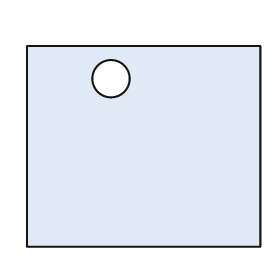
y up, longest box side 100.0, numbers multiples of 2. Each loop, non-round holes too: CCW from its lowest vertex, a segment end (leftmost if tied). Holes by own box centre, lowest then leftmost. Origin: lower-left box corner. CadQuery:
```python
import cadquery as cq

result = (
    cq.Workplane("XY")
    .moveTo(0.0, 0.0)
    .lineTo(100.0, 0.0)
    .lineTo(100.0, 86.0)
    .lineTo(0.0, 86.0)
    .close()
    .moveTo(36.0, 72.0)
    .circle(8.0)
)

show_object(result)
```